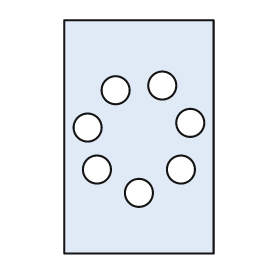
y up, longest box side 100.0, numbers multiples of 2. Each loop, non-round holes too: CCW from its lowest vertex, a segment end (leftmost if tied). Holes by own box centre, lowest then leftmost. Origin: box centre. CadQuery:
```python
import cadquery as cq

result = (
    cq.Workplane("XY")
    .moveTo(-32.0, -50.0)
    .lineTo(32.0, -50.0)
    .lineTo(32.0, 50.0)
    .lineTo(-32.0, 50.0)
    .close()
    .moveTo(0.0, -24.0)
    .circle(6.0)
    .moveTo(-18.0, -14.0)
    .circle(6.0)
    .moveTo(18.0, -14.0)
    .circle(6.0)
    .moveTo(-22.0, 4.0)
    .circle(6.0)
    .moveTo(22.0, 6.0)
    .circle(6.0)
    .moveTo(-10.0, 20.0)
    .circle(6.0)
    .moveTo(10.0, 22.0)
    .circle(6.0)
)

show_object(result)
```